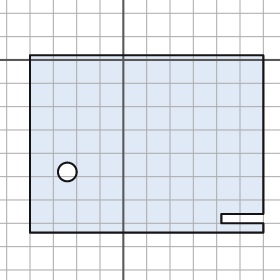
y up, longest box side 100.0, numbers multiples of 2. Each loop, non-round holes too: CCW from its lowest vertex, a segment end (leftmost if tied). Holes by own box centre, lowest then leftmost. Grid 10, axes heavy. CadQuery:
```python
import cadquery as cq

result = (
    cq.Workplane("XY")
    .moveTo(-40.0, -74.0)
    .lineTo(60.0, -74.0)
    .lineTo(60.0, -70.0)
    .lineTo(42.0, -70.0)
    .lineTo(42.0, -66.0)
    .lineTo(60.0, -66.0)
    .lineTo(60.0, 2.0)
    .lineTo(-40.0, 2.0)
    .close()
    .moveTo(-24.0, -48.0)
    .circle(4.0)
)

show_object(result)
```